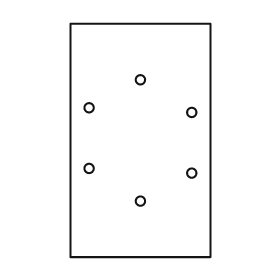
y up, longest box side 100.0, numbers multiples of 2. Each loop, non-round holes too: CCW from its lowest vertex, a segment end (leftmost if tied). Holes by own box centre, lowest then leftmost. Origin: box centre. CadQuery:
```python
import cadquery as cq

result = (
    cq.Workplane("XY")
    .moveTo(-30.0, -50.0)
    .lineTo(30.0, -50.0)
    .lineTo(30.0, 50.0)
    .lineTo(-30.0, 50.0)
    .close()
    .moveTo(0.0, -26.0)
    .circle(2.0)
    .moveTo(22.0, -14.0)
    .circle(2.0)
    .moveTo(-22.0, -12.0)
    .circle(2.0)
    .moveTo(22.0, 12.0)
    .circle(2.0)
    .moveTo(-22.0, 14.0)
    .circle(2.0)
    .moveTo(0.0, 26.0)
    .circle(2.0)
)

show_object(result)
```